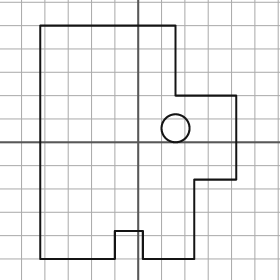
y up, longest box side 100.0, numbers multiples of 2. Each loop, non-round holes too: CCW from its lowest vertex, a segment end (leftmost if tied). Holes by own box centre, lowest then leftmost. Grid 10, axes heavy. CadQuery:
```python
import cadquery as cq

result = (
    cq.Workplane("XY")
    .moveTo(-42.0, -50.0)
    .lineTo(-10.0, -50.0)
    .lineTo(-10.0, -38.0)
    .lineTo(2.0, -38.0)
    .lineTo(2.0, -50.0)
    .lineTo(24.0, -50.0)
    .lineTo(24.0, -16.0)
    .lineTo(42.0, -16.0)
    .lineTo(42.0, 20.0)
    .lineTo(16.0, 20.0)
    .lineTo(16.0, 50.0)
    .lineTo(-42.0, 50.0)
    .close()
    .moveTo(16.0, 6.0)
    .circle(6.0)
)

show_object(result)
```